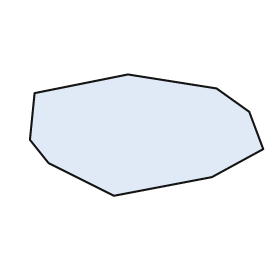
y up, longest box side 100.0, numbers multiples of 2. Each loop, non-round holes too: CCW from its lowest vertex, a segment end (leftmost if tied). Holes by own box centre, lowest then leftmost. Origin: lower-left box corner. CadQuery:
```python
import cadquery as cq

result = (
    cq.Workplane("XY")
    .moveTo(36.0, 0.0)
    .lineTo(78.0, 8.0)
    .lineTo(100.0, 20.0)
    .lineTo(94.0, 36.0)
    .lineTo(80.0, 46.0)
    .lineTo(42.0, 52.0)
    .lineTo(2.0, 44.0)
    .lineTo(0.0, 24.0)
    .lineTo(8.0, 14.0)
    .close()
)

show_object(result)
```